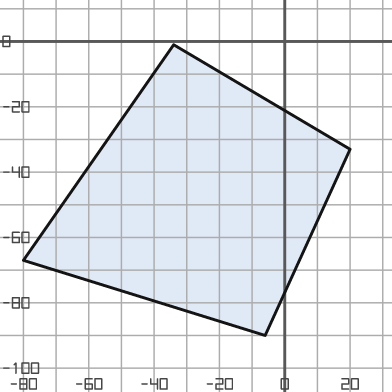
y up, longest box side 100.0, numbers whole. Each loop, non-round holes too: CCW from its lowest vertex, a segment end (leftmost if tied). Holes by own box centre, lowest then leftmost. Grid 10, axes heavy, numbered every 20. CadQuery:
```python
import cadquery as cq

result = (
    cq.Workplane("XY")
    .moveTo(-6.0, -90.0)
    .lineTo(20.0, -33.0)
    .lineTo(-34.0, -1.0)
    .lineTo(-80.0, -67.0)
    .close()
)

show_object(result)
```